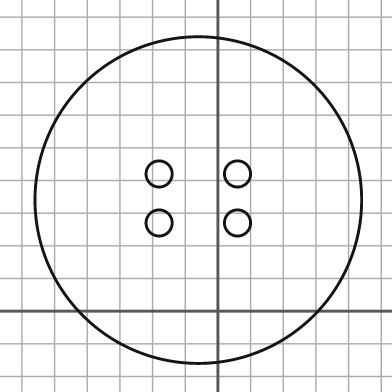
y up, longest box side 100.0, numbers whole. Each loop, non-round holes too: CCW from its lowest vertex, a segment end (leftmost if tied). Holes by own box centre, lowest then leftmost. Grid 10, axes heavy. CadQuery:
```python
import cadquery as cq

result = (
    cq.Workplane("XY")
    .moveTo(-6.0, 34.0)
    .circle(50.0)
    .moveTo(-18.0, 27.0)
    .circle(4.0)
    .moveTo(6.0, 27.0)
    .circle(4.0)
    .moveTo(-18.0, 42.0)
    .circle(4.0)
    .moveTo(6.0, 42.0)
    .circle(4.0)
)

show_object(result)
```